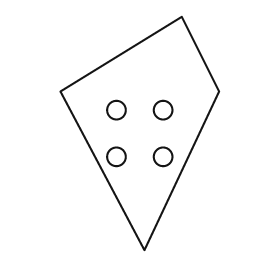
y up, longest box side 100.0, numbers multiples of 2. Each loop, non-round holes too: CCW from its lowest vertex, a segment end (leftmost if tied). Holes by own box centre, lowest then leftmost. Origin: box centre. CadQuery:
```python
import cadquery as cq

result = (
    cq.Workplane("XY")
    .moveTo(2.0, -50.0)
    .lineTo(34.0, 18.0)
    .lineTo(18.0, 50.0)
    .lineTo(-34.0, 18.0)
    .close()
    .moveTo(-10.0, -10.0)
    .circle(4.0)
    .moveTo(10.0, -10.0)
    .circle(4.0)
    .moveTo(-10.0, 10.0)
    .circle(4.0)
    .moveTo(10.0, 10.0)
    .circle(4.0)
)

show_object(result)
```